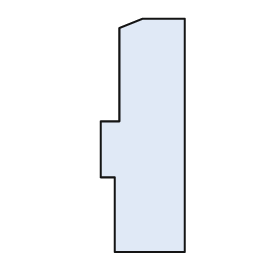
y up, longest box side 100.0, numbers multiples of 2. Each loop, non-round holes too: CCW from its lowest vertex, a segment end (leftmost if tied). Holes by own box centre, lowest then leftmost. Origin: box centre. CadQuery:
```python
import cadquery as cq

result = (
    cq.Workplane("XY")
    .moveTo(-12.0, -50.0)
    .lineTo(18.0, -50.0)
    .lineTo(18.0, 50.0)
    .lineTo(0.0, 50.0)
    .lineTo(-10.0, 46.0)
    .lineTo(-10.0, 6.0)
    .lineTo(-18.0, 6.0)
    .lineTo(-18.0, -18.0)
    .lineTo(-12.0, -18.0)
    .close()
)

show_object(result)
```